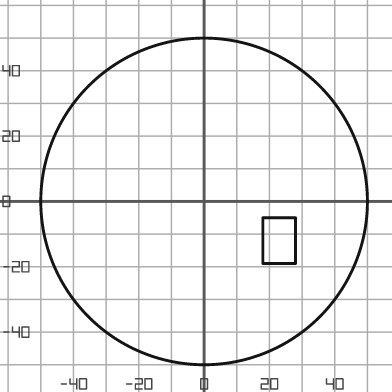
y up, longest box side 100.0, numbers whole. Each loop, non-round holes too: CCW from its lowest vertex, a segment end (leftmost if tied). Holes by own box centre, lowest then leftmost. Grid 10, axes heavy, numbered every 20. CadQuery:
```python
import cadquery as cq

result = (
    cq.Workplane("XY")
    .moveTo(0.0, 0.0)
    .circle(50.0)
    .moveTo(18.0, -19.0)
    .lineTo(28.0, -19.0)
    .lineTo(28.0, -5.0)
    .lineTo(18.0, -5.0)
    .close()
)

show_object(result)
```